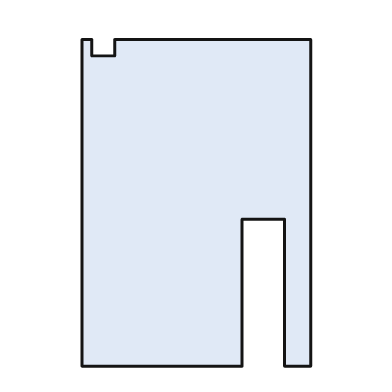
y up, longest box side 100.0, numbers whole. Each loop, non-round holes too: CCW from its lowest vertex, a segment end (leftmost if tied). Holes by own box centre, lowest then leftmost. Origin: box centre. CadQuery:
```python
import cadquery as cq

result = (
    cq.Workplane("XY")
    .moveTo(-35.0, -50.0)
    .lineTo(14.0, -50.0)
    .lineTo(14.0, -5.0)
    .lineTo(27.0, -5.0)
    .lineTo(27.0, -50.0)
    .lineTo(35.0, -50.0)
    .lineTo(35.0, 50.0)
    .lineTo(-25.0, 50.0)
    .lineTo(-25.0, 45.0)
    .lineTo(-32.0, 45.0)
    .lineTo(-32.0, 50.0)
    .lineTo(-35.0, 50.0)
    .close()
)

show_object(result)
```